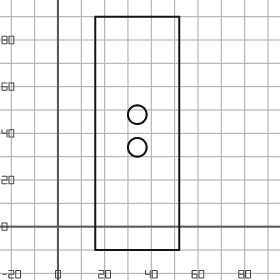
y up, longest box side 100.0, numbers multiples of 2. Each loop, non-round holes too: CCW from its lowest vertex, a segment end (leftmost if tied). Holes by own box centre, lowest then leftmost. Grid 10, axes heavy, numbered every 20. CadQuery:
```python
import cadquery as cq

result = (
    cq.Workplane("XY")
    .moveTo(16.0, -10.0)
    .lineTo(52.0, -10.0)
    .lineTo(52.0, 90.0)
    .lineTo(16.0, 90.0)
    .close()
    .moveTo(34.0, 34.0)
    .circle(4.0)
    .moveTo(34.0, 48.0)
    .circle(4.0)
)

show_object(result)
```